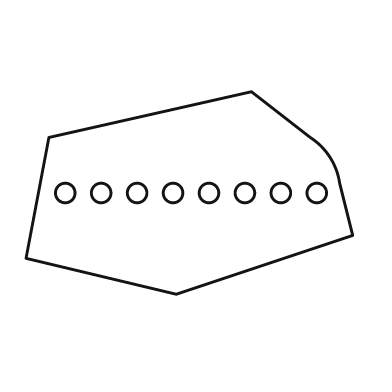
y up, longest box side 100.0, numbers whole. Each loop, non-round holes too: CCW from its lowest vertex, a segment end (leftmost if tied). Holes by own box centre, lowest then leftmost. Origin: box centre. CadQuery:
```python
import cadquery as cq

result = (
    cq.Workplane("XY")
    .moveTo(-4.0, -31.0)
    .lineTo(50.0, -13.0)
    .lineTo(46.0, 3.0)
    .threePointArc((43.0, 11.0), (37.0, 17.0))
    .lineTo(19.0, 31.0)
    .lineTo(-43.0, 17.0)
    .lineTo(-50.0, -20.0)
    .close()
    .moveTo(-38.0, 0.0)
    .circle(3.0)
    .moveTo(-27.0, 0.0)
    .circle(3.0)
    .moveTo(-16.0, 0.0)
    .circle(3.0)
    .moveTo(-5.0, 0.0)
    .circle(3.0)
    .moveTo(6.0, 0.0)
    .circle(3.0)
    .moveTo(17.0, 0.0)
    .circle(3.0)
    .moveTo(28.0, 0.0)
    .circle(3.0)
    .moveTo(39.0, 0.0)
    .circle(3.0)
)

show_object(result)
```